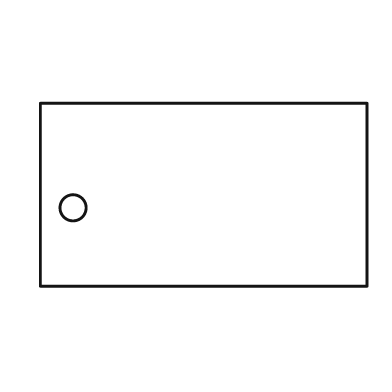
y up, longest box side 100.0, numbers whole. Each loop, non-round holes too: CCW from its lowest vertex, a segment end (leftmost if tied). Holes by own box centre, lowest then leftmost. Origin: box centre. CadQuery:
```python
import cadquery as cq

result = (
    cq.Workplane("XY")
    .moveTo(-50.0, -28.0)
    .lineTo(50.0, -28.0)
    .lineTo(50.0, 28.0)
    .lineTo(-50.0, 28.0)
    .close()
    .moveTo(-40.0, -4.0)
    .circle(4.0)
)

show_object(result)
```